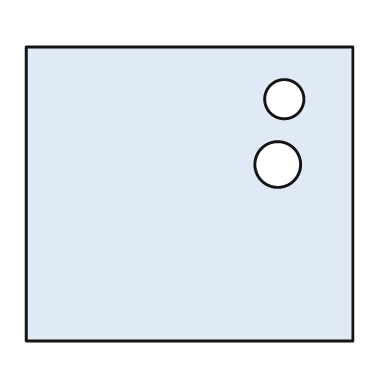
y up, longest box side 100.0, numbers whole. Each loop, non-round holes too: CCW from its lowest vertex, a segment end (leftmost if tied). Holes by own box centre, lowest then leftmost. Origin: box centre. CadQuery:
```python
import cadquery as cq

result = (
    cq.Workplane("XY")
    .moveTo(-50.0, -45.0)
    .lineTo(50.0, -45.0)
    .lineTo(50.0, 45.0)
    .lineTo(-50.0, 45.0)
    .close()
    .moveTo(27.0, 9.0)
    .circle(7.0)
    .moveTo(29.0, 29.0)
    .circle(6.0)
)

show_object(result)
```